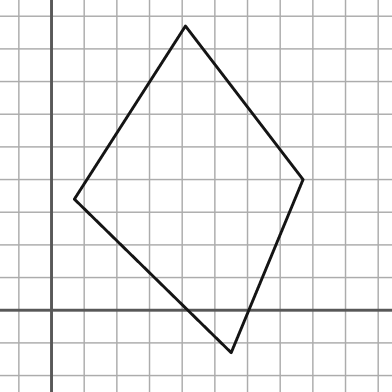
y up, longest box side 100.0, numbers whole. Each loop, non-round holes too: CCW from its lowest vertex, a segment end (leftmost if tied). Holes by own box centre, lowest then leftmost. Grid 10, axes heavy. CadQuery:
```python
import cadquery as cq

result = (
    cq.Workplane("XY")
    .moveTo(55.0, -13.0)
    .lineTo(77.0, 40.0)
    .lineTo(41.0, 87.0)
    .lineTo(7.0, 34.0)
    .close()
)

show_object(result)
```